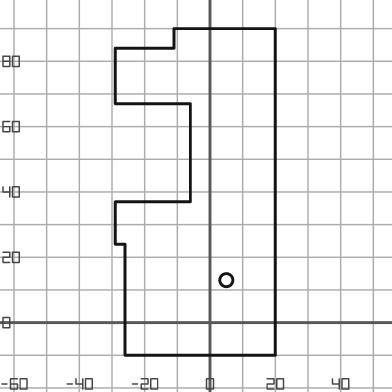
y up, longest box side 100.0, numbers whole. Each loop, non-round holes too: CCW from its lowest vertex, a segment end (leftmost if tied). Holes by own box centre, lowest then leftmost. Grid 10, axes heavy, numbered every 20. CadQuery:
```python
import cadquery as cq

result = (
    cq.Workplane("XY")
    .moveTo(-26.0, -10.0)
    .lineTo(20.0, -10.0)
    .lineTo(20.0, 90.0)
    .lineTo(-11.0, 90.0)
    .lineTo(-11.0, 84.0)
    .lineTo(-29.0, 84.0)
    .lineTo(-29.0, 67.0)
    .lineTo(-6.0, 67.0)
    .lineTo(-6.0, 37.0)
    .lineTo(-29.0, 37.0)
    .lineTo(-29.0, 24.0)
    .lineTo(-26.0, 24.0)
    .close()
    .moveTo(5.0, 13.0)
    .circle(2.0)
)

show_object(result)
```